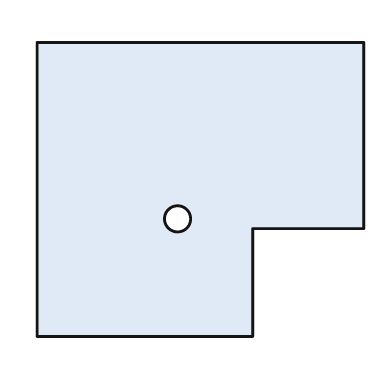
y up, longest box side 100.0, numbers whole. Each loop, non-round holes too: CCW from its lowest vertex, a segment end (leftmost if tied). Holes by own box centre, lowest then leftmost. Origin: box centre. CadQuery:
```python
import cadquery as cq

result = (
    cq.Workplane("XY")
    .moveTo(-50.0, -45.0)
    .lineTo(16.0, -45.0)
    .lineTo(16.0, -12.0)
    .lineTo(50.0, -12.0)
    .lineTo(50.0, 45.0)
    .lineTo(-50.0, 45.0)
    .close()
    .moveTo(-7.0, -9.0)
    .circle(4.0)
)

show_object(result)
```